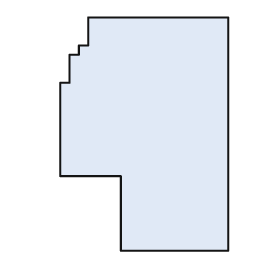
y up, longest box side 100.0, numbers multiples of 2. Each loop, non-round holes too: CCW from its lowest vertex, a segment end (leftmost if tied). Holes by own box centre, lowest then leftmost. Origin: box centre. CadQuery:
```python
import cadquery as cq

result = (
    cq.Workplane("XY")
    .moveTo(-10.0, -50.0)
    .lineTo(36.0, -50.0)
    .lineTo(36.0, 50.0)
    .lineTo(-24.0, 50.0)
    .lineTo(-24.0, 38.0)
    .lineTo(-28.0, 38.0)
    .lineTo(-28.0, 34.0)
    .lineTo(-32.0, 34.0)
    .lineTo(-32.0, 22.0)
    .lineTo(-36.0, 22.0)
    .lineTo(-36.0, -18.0)
    .lineTo(-10.0, -18.0)
    .close()
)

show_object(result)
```